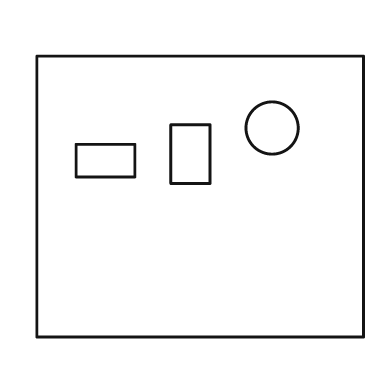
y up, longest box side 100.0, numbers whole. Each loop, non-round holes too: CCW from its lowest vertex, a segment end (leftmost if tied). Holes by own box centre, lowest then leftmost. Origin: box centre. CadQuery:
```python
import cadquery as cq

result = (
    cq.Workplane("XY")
    .moveTo(-50.0, -43.0)
    .lineTo(50.0, -43.0)
    .lineTo(50.0, 43.0)
    .lineTo(-50.0, 43.0)
    .close()
    .moveTo(-38.0, 6.0)
    .lineTo(-20.0, 6.0)
    .lineTo(-20.0, 16.0)
    .lineTo(-38.0, 16.0)
    .close()
    .moveTo(-9.0, 4.0)
    .lineTo(3.0, 4.0)
    .lineTo(3.0, 22.0)
    .lineTo(-9.0, 22.0)
    .close()
    .moveTo(22.0, 21.0)
    .circle(8.0)
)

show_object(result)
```